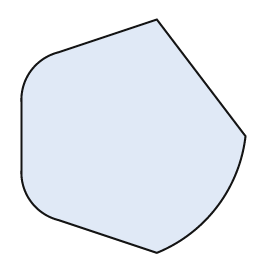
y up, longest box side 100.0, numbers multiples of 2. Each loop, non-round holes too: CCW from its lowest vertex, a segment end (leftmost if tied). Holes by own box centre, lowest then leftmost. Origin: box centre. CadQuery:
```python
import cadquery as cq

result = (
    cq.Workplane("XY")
    .moveTo(10.0, -50.0)
    .threePointArc((36.0, -30.0), (48.0, 0.0))
    .lineTo(10.0, 50.0)
    .lineTo(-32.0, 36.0)
    .threePointArc((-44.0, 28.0), (-48.0, 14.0))
    .lineTo(-48.0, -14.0)
    .threePointArc((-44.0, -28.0), (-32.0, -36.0))
    .close()
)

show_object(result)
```